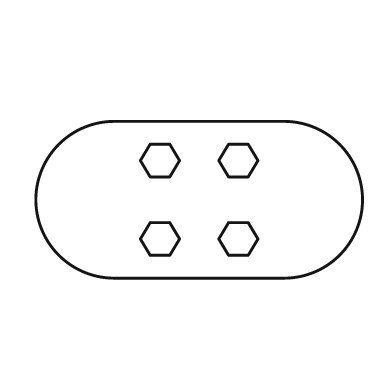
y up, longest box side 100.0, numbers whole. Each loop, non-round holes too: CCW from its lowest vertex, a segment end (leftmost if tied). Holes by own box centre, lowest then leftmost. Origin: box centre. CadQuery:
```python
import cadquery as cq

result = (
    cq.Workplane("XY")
    .moveTo(-26.0, -24.0)
    .lineTo(26.0, -24.0)
    .threePointArc((50.0, 0.0), (26.0, 24.0))
    .lineTo(-26.0, 24.0)
    .threePointArc((-50.0, 0.0), (-26.0, -24.0))
    .close()
    .moveTo(-15.0, -17.0)
    .lineTo(-9.0, -17.0)
    .lineTo(-6.0, -12.0)
    .lineTo(-9.0, -7.0)
    .lineTo(-15.0, -7.0)
    .lineTo(-18.0, -12.0)
    .close()
    .moveTo(9.0, -17.0)
    .lineTo(15.0, -17.0)
    .lineTo(18.0, -12.0)
    .lineTo(15.0, -7.0)
    .lineTo(9.0, -7.0)
    .lineTo(6.0, -12.0)
    .close()
    .moveTo(-15.0, 7.0)
    .lineTo(-9.0, 7.0)
    .lineTo(-6.0, 12.0)
    .lineTo(-9.0, 17.0)
    .lineTo(-15.0, 17.0)
    .lineTo(-18.0, 12.0)
    .close()
    .moveTo(9.0, 7.0)
    .lineTo(15.0, 7.0)
    .lineTo(18.0, 12.0)
    .lineTo(15.0, 17.0)
    .lineTo(9.0, 17.0)
    .lineTo(6.0, 12.0)
    .close()
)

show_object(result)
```